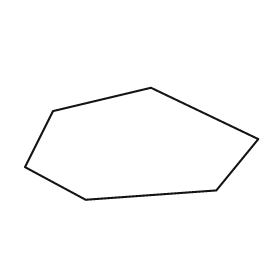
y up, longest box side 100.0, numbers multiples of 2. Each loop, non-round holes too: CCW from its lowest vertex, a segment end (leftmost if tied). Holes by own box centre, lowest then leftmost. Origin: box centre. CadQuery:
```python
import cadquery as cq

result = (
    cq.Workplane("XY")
    .moveTo(-24.0, -24.0)
    .lineTo(32.0, -20.0)
    .lineTo(50.0, 2.0)
    .lineTo(4.0, 24.0)
    .lineTo(-38.0, 14.0)
    .lineTo(-50.0, -10.0)
    .close()
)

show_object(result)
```